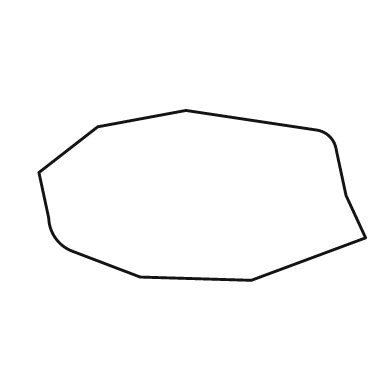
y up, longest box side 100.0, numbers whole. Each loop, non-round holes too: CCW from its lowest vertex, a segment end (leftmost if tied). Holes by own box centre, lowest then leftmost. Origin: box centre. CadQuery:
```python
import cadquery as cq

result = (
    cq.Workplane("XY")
    .moveTo(15.0, -26.0)
    .lineTo(50.0, -13.0)
    .lineTo(44.0, 0.0)
    .lineTo(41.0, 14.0)
    .threePointArc((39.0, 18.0), (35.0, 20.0))
    .lineTo(-5.0, 26.0)
    .lineTo(-32.0, 21.0)
    .lineTo(-50.0, 7.0)
    .lineTo(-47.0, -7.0)
    .threePointArc((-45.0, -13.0), (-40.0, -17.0))
    .lineTo(-19.0, -25.0)
    .close()
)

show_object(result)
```